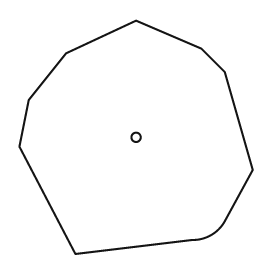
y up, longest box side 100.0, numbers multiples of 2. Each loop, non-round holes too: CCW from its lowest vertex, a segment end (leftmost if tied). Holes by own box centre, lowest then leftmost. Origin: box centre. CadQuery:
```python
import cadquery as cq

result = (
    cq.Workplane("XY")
    .moveTo(-26.0, -50.0)
    .lineTo(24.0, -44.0)
    .threePointArc((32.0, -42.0), (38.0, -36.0))
    .lineTo(50.0, -14.0)
    .lineTo(38.0, 28.0)
    .lineTo(28.0, 38.0)
    .lineTo(0.0, 50.0)
    .lineTo(-30.0, 36.0)
    .lineTo(-46.0, 16.0)
    .lineTo(-50.0, -4.0)
    .close()
    .moveTo(0.0, 0.0)
    .circle(2.0)
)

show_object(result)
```